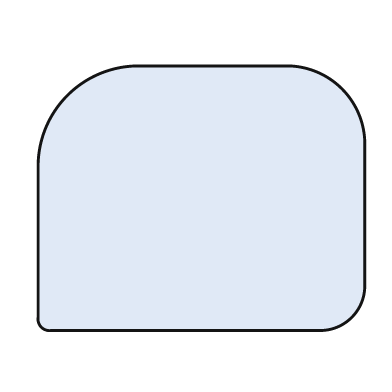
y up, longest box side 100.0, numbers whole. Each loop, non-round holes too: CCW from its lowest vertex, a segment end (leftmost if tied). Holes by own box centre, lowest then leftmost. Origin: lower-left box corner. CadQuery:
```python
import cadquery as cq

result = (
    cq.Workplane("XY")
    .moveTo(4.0, 0.0)
    .lineTo(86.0, 0.0)
    .threePointArc((96.0, 4.0), (100.0, 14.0))
    .lineTo(100.0, 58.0)
    .threePointArc((93.0, 74.0), (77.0, 81.0))
    .lineTo(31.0, 81.0)
    .threePointArc((9.0, 72.0), (0.0, 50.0))
    .lineTo(0.0, 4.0)
    .threePointArc((1.0, 1.0), (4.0, 0.0))
    .close()
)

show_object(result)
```